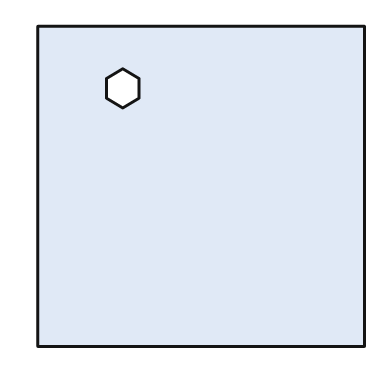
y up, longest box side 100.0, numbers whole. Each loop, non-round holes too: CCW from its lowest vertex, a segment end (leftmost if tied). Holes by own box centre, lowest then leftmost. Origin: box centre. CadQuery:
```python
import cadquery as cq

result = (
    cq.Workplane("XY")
    .moveTo(-50.0, -49.0)
    .lineTo(50.0, -49.0)
    .lineTo(50.0, 49.0)
    .lineTo(-50.0, 49.0)
    .close()
    .moveTo(-24.0, 24.0)
    .lineTo(-19.0, 27.0)
    .lineTo(-19.0, 33.0)
    .lineTo(-24.0, 36.0)
    .lineTo(-29.0, 33.0)
    .lineTo(-29.0, 27.0)
    .close()
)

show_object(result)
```